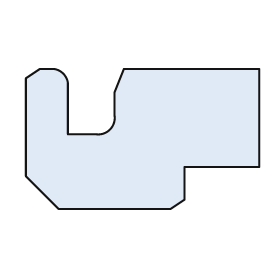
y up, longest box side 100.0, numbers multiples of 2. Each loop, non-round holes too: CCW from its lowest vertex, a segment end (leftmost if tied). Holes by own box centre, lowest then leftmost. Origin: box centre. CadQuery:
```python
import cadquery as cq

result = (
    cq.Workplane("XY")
    .moveTo(-36.0, -30.0)
    .lineTo(12.0, -30.0)
    .lineTo(18.0, -26.0)
    .lineTo(18.0, -12.0)
    .lineTo(50.0, -12.0)
    .lineTo(50.0, 30.0)
    .lineTo(-8.0, 30.0)
    .lineTo(-12.0, 20.0)
    .lineTo(-12.0, 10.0)
    .threePointArc((-14.0, 4.0), (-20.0, 2.0))
    .lineTo(-32.0, 2.0)
    .lineTo(-32.0, 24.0)
    .threePointArc((-34.0, 28.0), (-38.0, 30.0))
    .lineTo(-44.0, 30.0)
    .lineTo(-50.0, 26.0)
    .lineTo(-50.0, -16.0)
    .close()
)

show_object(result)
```